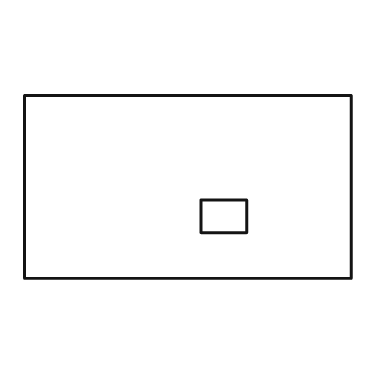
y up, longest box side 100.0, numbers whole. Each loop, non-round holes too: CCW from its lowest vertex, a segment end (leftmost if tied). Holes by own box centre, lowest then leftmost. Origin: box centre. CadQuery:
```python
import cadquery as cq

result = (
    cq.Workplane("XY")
    .moveTo(-50.0, -28.0)
    .lineTo(50.0, -28.0)
    .lineTo(50.0, 28.0)
    .lineTo(-50.0, 28.0)
    .close()
    .moveTo(4.0, -14.0)
    .lineTo(18.0, -14.0)
    .lineTo(18.0, -4.0)
    .lineTo(4.0, -4.0)
    .close()
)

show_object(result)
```